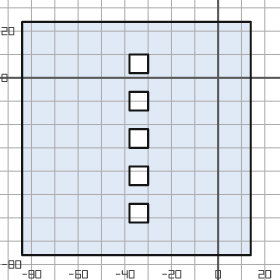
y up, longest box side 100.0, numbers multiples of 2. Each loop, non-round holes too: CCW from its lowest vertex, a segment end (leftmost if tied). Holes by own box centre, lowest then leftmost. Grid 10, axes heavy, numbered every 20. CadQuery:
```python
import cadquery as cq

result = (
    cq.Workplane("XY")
    .moveTo(-84.0, -76.0)
    .lineTo(14.0, -76.0)
    .lineTo(14.0, 24.0)
    .lineTo(-84.0, 24.0)
    .close()
    .moveTo(-38.0, -62.0)
    .lineTo(-30.0, -62.0)
    .lineTo(-30.0, -54.0)
    .lineTo(-38.0, -54.0)
    .close()
    .moveTo(-38.0, -46.0)
    .lineTo(-30.0, -46.0)
    .lineTo(-30.0, -38.0)
    .lineTo(-38.0, -38.0)
    .close()
    .moveTo(-38.0, -30.0)
    .lineTo(-30.0, -30.0)
    .lineTo(-30.0, -22.0)
    .lineTo(-38.0, -22.0)
    .close()
    .moveTo(-38.0, -14.0)
    .lineTo(-30.0, -14.0)
    .lineTo(-30.0, -6.0)
    .lineTo(-38.0, -6.0)
    .close()
    .moveTo(-38.0, 2.0)
    .lineTo(-30.0, 2.0)
    .lineTo(-30.0, 10.0)
    .lineTo(-38.0, 10.0)
    .close()
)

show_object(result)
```